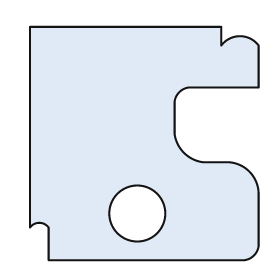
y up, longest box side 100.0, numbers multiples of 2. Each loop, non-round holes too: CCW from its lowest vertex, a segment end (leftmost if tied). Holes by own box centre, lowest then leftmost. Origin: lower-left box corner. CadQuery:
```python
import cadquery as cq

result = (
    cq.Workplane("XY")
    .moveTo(8.0, 0.0)
    .lineTo(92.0, 0.0)
    .threePointArc((96.0, 2.0), (98.0, 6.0))
    .lineTo(98.0, 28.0)
    .threePointArc((94.0, 38.0), (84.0, 42.0))
    .lineTo(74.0, 42.0)
    .threePointArc((66.0, 46.0), (62.0, 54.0))
    .lineTo(62.0, 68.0)
    .threePointArc((64.0, 72.0), (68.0, 74.0))
    .lineTo(98.0, 74.0)
    .lineTo(98.0, 92.0)
    .threePointArc((90.0, 96.0), (82.0, 92.0))
    .lineTo(82.0, 100.0)
    .lineTo(0.0, 100.0)
    .lineTo(0.0, 14.0)
    .threePointArc((4.0, 16.0), (8.0, 14.0))
    .close()
    .moveTo(46.0, 20.0)
    .circle(12.0)
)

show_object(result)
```